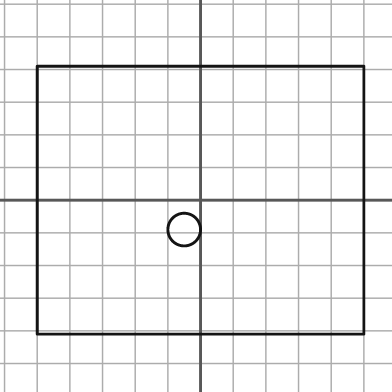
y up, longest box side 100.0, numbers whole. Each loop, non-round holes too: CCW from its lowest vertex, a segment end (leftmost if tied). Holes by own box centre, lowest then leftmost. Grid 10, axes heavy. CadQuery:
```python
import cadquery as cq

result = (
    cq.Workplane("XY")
    .moveTo(-50.0, -41.0)
    .lineTo(50.0, -41.0)
    .lineTo(50.0, 41.0)
    .lineTo(-50.0, 41.0)
    .close()
    .moveTo(-5.0, -9.0)
    .circle(5.0)
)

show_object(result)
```